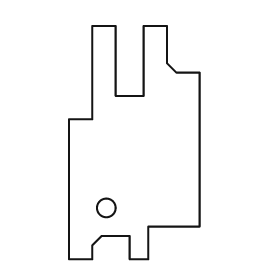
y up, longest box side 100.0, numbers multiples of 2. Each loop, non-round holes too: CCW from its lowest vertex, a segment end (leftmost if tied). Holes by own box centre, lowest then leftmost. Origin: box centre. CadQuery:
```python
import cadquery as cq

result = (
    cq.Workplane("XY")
    .moveTo(-28.0, -50.0)
    .lineTo(-18.0, -50.0)
    .lineTo(-18.0, -44.0)
    .lineTo(-14.0, -40.0)
    .lineTo(-2.0, -40.0)
    .lineTo(-2.0, -50.0)
    .lineTo(6.0, -50.0)
    .lineTo(6.0, -36.0)
    .lineTo(28.0, -36.0)
    .lineTo(28.0, 30.0)
    .lineTo(18.0, 30.0)
    .lineTo(14.0, 34.0)
    .lineTo(14.0, 50.0)
    .lineTo(4.0, 50.0)
    .lineTo(4.0, 20.0)
    .lineTo(-8.0, 20.0)
    .lineTo(-8.0, 50.0)
    .lineTo(-18.0, 50.0)
    .lineTo(-18.0, 10.0)
    .lineTo(-28.0, 10.0)
    .close()
    .moveTo(-12.0, -28.0)
    .circle(4.0)
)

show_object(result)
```